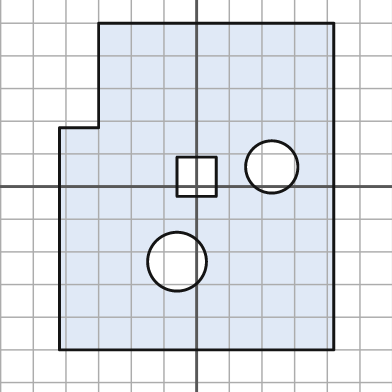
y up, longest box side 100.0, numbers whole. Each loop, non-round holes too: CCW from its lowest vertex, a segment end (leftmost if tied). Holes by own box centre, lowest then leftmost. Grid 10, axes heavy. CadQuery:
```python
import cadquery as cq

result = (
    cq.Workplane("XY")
    .moveTo(-42.0, -50.0)
    .lineTo(42.0, -50.0)
    .lineTo(42.0, 50.0)
    .lineTo(-30.0, 50.0)
    .lineTo(-30.0, 18.0)
    .lineTo(-42.0, 18.0)
    .close()
    .moveTo(-6.0, -23.0)
    .circle(9.0)
    .moveTo(-6.0, -3.0)
    .lineTo(6.0, -3.0)
    .lineTo(6.0, 9.0)
    .lineTo(-6.0, 9.0)
    .close()
    .moveTo(23.0, 6.0)
    .circle(8.0)
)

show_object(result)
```